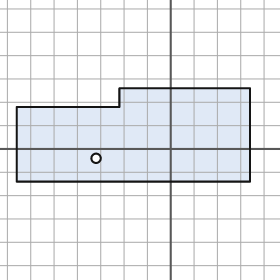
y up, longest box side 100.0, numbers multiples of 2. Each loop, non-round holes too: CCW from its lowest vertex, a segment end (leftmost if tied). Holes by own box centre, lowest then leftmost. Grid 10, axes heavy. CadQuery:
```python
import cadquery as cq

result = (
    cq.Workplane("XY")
    .moveTo(-66.0, -14.0)
    .lineTo(34.0, -14.0)
    .lineTo(34.0, 26.0)
    .lineTo(-22.0, 26.0)
    .lineTo(-22.0, 18.0)
    .lineTo(-66.0, 18.0)
    .close()
    .moveTo(-32.0, -4.0)
    .circle(2.0)
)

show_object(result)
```